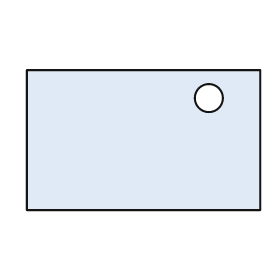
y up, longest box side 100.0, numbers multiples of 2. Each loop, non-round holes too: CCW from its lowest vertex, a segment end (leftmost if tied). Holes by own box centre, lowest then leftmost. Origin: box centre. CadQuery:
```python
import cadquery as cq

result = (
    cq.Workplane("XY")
    .moveTo(-50.0, -30.0)
    .lineTo(50.0, -30.0)
    .lineTo(50.0, 30.0)
    .lineTo(-50.0, 30.0)
    .close()
    .moveTo(28.0, 18.0)
    .circle(6.0)
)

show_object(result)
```